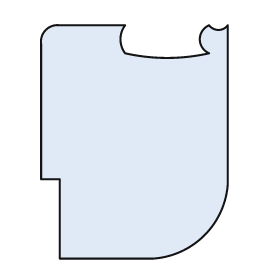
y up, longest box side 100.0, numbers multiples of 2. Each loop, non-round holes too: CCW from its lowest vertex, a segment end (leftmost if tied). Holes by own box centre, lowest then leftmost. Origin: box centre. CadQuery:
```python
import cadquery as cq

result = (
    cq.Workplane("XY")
    .moveTo(-32.0, -50.0)
    .lineTo(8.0, -50.0)
    .threePointArc((30.0, -40.0), (40.0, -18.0))
    .lineTo(40.0, 50.0)
    .threePointArc((36.0, 48.0), (32.0, 50.0))
    .threePointArc((28.0, 44.0), (32.0, 38.0))
    .threePointArc((14.0, 36.0), (-4.0, 38.0))
    .threePointArc((-6.0, 44.0), (-4.0, 50.0))
    .lineTo(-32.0, 50.0)
    .threePointArc((-38.0, 48.0), (-40.0, 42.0))
    .lineTo(-40.0, -16.0)
    .lineTo(-32.0, -16.0)
    .close()
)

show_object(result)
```